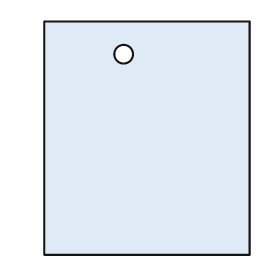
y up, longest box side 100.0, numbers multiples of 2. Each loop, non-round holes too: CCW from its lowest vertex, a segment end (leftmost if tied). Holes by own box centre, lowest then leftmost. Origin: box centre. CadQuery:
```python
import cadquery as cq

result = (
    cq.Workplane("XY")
    .moveTo(-44.0, -50.0)
    .lineTo(44.0, -50.0)
    .lineTo(44.0, 50.0)
    .lineTo(-44.0, 50.0)
    .close()
    .moveTo(-10.0, 36.0)
    .circle(4.0)
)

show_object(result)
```